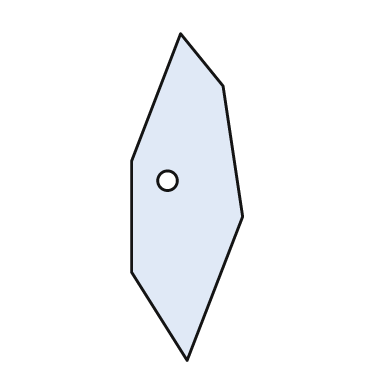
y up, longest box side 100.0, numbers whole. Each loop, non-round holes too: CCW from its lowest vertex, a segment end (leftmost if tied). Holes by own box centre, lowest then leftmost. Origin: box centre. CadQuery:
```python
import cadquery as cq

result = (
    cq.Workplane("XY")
    .moveTo(0.0, -50.0)
    .lineTo(17.0, -6.0)
    .lineTo(11.0, 34.0)
    .lineTo(-2.0, 50.0)
    .lineTo(-17.0, 11.0)
    .lineTo(-17.0, -23.0)
    .close()
    .moveTo(-6.0, 5.0)
    .circle(3.0)
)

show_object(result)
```